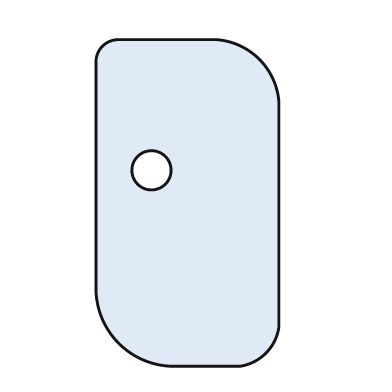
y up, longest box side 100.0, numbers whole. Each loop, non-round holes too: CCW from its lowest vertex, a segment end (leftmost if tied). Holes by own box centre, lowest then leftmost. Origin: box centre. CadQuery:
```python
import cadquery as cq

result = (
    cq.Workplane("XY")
    .moveTo(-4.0, -50.0)
    .lineTo(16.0, -50.0)
    .threePointArc((24.0, -46.0), (28.0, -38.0))
    .lineTo(28.0, 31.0)
    .threePointArc((22.0, 44.0), (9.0, 50.0))
    .lineTo(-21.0, 50.0)
    .threePointArc((-26.0, 48.0), (-28.0, 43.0))
    .lineTo(-28.0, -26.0)
    .threePointArc((-21.0, -43.0), (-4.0, -50.0))
    .close()
    .moveTo(-11.0, 10.0)
    .circle(6.0)
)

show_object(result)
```